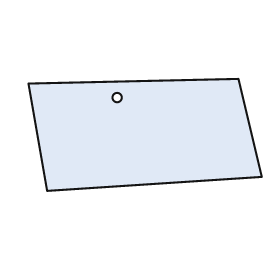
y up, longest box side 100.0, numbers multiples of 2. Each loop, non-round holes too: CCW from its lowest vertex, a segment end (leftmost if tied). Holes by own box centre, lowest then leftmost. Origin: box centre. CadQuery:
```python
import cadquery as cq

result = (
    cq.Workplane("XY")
    .moveTo(-42.0, -24.0)
    .lineTo(50.0, -18.0)
    .lineTo(40.0, 24.0)
    .lineTo(-50.0, 22.0)
    .close()
    .moveTo(-12.0, 16.0)
    .circle(2.0)
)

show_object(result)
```